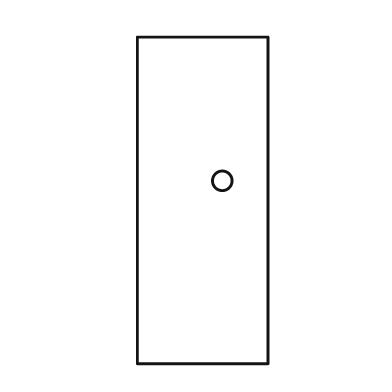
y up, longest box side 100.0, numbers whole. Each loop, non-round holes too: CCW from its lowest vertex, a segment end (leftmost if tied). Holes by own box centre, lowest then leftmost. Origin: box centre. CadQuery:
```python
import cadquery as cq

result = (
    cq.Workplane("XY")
    .moveTo(-20.0, -50.0)
    .lineTo(20.0, -50.0)
    .lineTo(20.0, 50.0)
    .lineTo(-20.0, 50.0)
    .close()
    .moveTo(6.0, 6.0)
    .circle(3.0)
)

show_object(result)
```